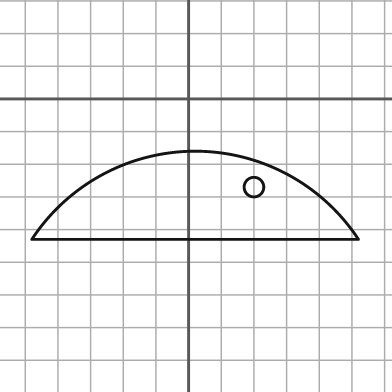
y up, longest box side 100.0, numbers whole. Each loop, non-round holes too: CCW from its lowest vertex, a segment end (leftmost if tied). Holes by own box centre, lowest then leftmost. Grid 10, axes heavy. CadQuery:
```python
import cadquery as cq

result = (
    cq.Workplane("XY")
    .moveTo(-48.0, -43.0)
    .lineTo(52.0, -43.0)
    .threePointArc((2.0, -16.0), (-48.0, -43.0))
    .close()
    .moveTo(20.0, -27.0)
    .circle(3.0)
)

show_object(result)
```